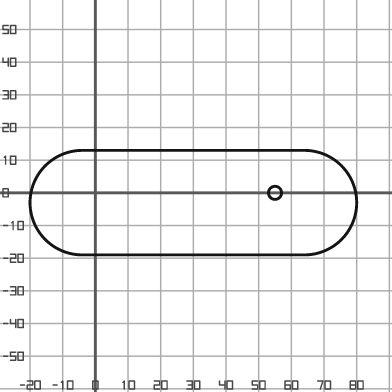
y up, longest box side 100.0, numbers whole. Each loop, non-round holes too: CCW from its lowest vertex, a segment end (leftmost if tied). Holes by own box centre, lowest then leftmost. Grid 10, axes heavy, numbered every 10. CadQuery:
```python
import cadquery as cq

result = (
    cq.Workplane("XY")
    .moveTo(-4.0, -19.0)
    .lineTo(64.0, -19.0)
    .threePointArc((80.0, -3.0), (64.0, 13.0))
    .lineTo(-4.0, 13.0)
    .threePointArc((-20.0, -3.0), (-4.0, -19.0))
    .close()
    .moveTo(55.0, 0.0)
    .circle(2.0)
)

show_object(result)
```